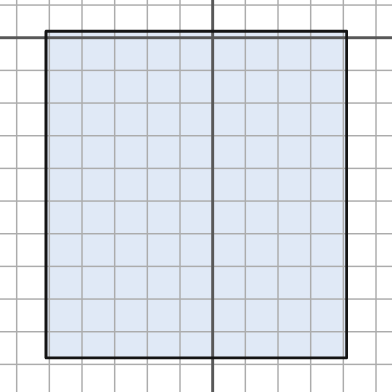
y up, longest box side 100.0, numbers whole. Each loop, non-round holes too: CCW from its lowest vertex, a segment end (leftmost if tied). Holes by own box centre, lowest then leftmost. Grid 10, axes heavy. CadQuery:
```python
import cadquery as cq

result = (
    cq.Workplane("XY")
    .moveTo(-51.0, -98.0)
    .lineTo(41.0, -98.0)
    .lineTo(41.0, 2.0)
    .lineTo(-51.0, 2.0)
    .close()
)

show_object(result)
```